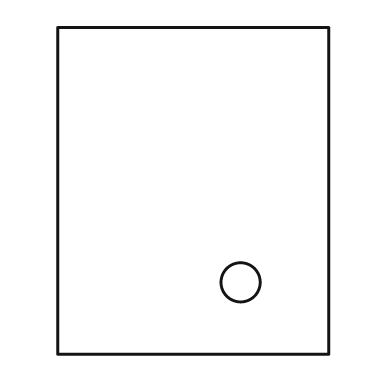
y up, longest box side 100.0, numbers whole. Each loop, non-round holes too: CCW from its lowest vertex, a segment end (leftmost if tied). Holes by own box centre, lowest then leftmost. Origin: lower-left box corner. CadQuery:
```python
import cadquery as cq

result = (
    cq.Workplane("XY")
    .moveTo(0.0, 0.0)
    .lineTo(83.0, 0.0)
    .lineTo(83.0, 100.0)
    .lineTo(0.0, 100.0)
    .close()
    .moveTo(56.0, 22.0)
    .circle(6.0)
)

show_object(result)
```